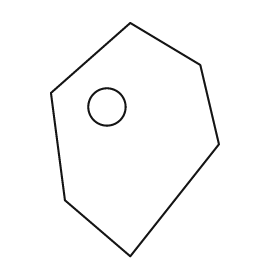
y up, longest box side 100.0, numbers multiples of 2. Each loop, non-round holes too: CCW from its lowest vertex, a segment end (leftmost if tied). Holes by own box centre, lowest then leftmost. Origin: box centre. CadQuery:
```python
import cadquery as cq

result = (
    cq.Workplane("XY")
    .moveTo(-2.0, -50.0)
    .lineTo(36.0, -2.0)
    .lineTo(28.0, 32.0)
    .lineTo(-2.0, 50.0)
    .lineTo(-36.0, 20.0)
    .lineTo(-30.0, -26.0)
    .close()
    .moveTo(-12.0, 14.0)
    .circle(8.0)
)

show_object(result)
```